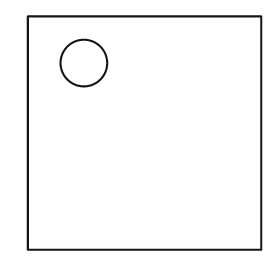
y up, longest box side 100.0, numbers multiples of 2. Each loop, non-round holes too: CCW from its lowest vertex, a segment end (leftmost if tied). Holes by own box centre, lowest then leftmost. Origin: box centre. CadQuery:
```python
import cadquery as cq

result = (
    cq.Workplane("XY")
    .moveTo(-50.0, -50.0)
    .lineTo(50.0, -50.0)
    .lineTo(50.0, 50.0)
    .lineTo(-50.0, 50.0)
    .close()
    .moveTo(-26.0, 30.0)
    .circle(10.0)
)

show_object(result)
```